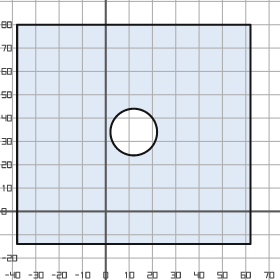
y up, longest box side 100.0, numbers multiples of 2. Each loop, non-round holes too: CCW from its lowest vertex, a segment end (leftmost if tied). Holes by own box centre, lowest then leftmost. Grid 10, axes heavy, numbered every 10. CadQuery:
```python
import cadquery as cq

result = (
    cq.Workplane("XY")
    .moveTo(-38.0, -14.0)
    .lineTo(62.0, -14.0)
    .lineTo(62.0, 80.0)
    .lineTo(-38.0, 80.0)
    .close()
    .moveTo(12.0, 34.0)
    .circle(10.0)
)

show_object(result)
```